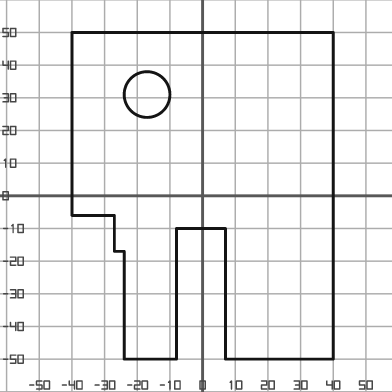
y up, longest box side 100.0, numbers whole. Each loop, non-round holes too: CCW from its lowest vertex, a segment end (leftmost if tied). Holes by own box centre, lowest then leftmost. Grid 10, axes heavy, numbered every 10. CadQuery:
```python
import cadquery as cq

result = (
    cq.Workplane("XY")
    .moveTo(-24.0, -50.0)
    .lineTo(-8.0, -50.0)
    .lineTo(-8.0, -10.0)
    .lineTo(7.0, -10.0)
    .lineTo(7.0, -50.0)
    .lineTo(40.0, -50.0)
    .lineTo(40.0, 50.0)
    .lineTo(-40.0, 50.0)
    .lineTo(-40.0, -6.0)
    .lineTo(-27.0, -6.0)
    .lineTo(-27.0, -17.0)
    .lineTo(-24.0, -17.0)
    .close()
    .moveTo(-17.0, 31.0)
    .circle(7.0)
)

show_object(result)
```